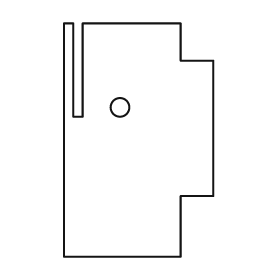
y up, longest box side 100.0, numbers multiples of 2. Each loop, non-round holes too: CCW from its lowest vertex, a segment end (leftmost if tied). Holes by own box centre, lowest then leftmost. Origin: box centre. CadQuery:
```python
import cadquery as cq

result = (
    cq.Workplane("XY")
    .moveTo(-32.0, -50.0)
    .lineTo(18.0, -50.0)
    .lineTo(18.0, -24.0)
    .lineTo(32.0, -24.0)
    .lineTo(32.0, 34.0)
    .lineTo(18.0, 34.0)
    .lineTo(18.0, 50.0)
    .lineTo(-24.0, 50.0)
    .lineTo(-24.0, 10.0)
    .lineTo(-28.0, 10.0)
    .lineTo(-28.0, 50.0)
    .lineTo(-32.0, 50.0)
    .close()
    .moveTo(-8.0, 14.0)
    .circle(4.0)
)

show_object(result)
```